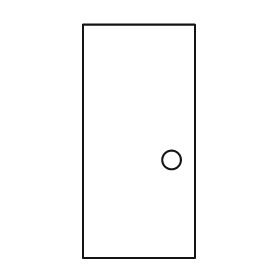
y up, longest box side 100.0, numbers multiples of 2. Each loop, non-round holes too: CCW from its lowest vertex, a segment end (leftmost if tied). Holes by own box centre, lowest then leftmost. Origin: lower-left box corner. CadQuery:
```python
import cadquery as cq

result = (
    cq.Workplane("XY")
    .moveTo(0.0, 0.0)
    .lineTo(48.0, 0.0)
    .lineTo(48.0, 100.0)
    .lineTo(0.0, 100.0)
    .close()
    .moveTo(38.0, 42.0)
    .circle(4.0)
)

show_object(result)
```